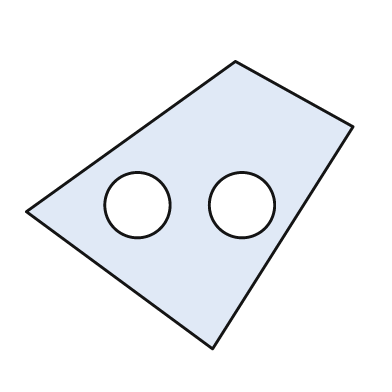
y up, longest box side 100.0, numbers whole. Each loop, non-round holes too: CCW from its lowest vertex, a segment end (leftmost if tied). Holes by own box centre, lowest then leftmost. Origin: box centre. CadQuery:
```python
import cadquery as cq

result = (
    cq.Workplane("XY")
    .moveTo(7.0, -44.0)
    .lineTo(50.0, 24.0)
    .lineTo(14.0, 44.0)
    .lineTo(-50.0, -2.0)
    .close()
    .moveTo(-16.0, 0.0)
    .circle(10.0)
    .moveTo(16.0, 0.0)
    .circle(10.0)
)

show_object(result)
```